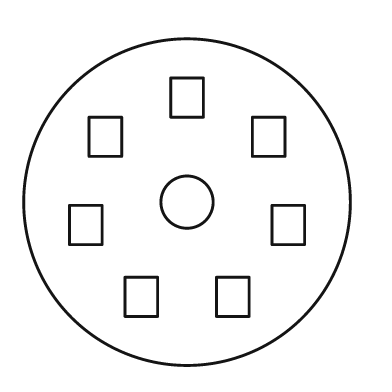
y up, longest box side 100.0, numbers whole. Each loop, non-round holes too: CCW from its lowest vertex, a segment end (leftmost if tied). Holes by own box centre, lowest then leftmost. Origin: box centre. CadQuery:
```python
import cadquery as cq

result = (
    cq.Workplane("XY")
    .moveTo(0.0, 0.0)
    .circle(50.0)
    .moveTo(-19.0, -35.0)
    .lineTo(-9.0, -35.0)
    .lineTo(-9.0, -23.0)
    .lineTo(-19.0, -23.0)
    .close()
    .moveTo(9.0, -35.0)
    .lineTo(19.0, -35.0)
    .lineTo(19.0, -23.0)
    .lineTo(9.0, -23.0)
    .close()
    .moveTo(-36.0, -13.0)
    .lineTo(-26.0, -13.0)
    .lineTo(-26.0, -1.0)
    .lineTo(-36.0, -1.0)
    .close()
    .moveTo(26.0, -13.0)
    .lineTo(36.0, -13.0)
    .lineTo(36.0, -1.0)
    .lineTo(26.0, -1.0)
    .close()
    .moveTo(0.0, 0.0)
    .circle(8.0)
    .moveTo(-30.0, 14.0)
    .lineTo(-20.0, 14.0)
    .lineTo(-20.0, 26.0)
    .lineTo(-30.0, 26.0)
    .close()
    .moveTo(20.0, 14.0)
    .lineTo(30.0, 14.0)
    .lineTo(30.0, 26.0)
    .lineTo(20.0, 26.0)
    .close()
    .moveTo(-5.0, 26.0)
    .lineTo(5.0, 26.0)
    .lineTo(5.0, 38.0)
    .lineTo(-5.0, 38.0)
    .close()
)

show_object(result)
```